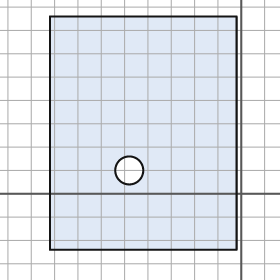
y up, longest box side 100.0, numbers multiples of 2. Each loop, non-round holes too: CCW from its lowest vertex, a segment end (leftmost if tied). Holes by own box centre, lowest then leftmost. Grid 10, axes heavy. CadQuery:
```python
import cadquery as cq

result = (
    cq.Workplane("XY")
    .moveTo(-82.0, -24.0)
    .lineTo(-2.0, -24.0)
    .lineTo(-2.0, 76.0)
    .lineTo(-82.0, 76.0)
    .close()
    .moveTo(-48.0, 10.0)
    .circle(6.0)
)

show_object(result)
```